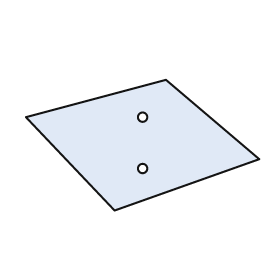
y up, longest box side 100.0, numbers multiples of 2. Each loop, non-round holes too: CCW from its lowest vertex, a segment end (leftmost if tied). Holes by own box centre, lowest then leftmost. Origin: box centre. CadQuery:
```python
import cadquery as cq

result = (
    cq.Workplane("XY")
    .moveTo(-12.0, -28.0)
    .lineTo(50.0, -6.0)
    .lineTo(10.0, 28.0)
    .lineTo(-50.0, 12.0)
    .close()
    .moveTo(0.0, -10.0)
    .circle(2.0)
    .moveTo(0.0, 12.0)
    .circle(2.0)
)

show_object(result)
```